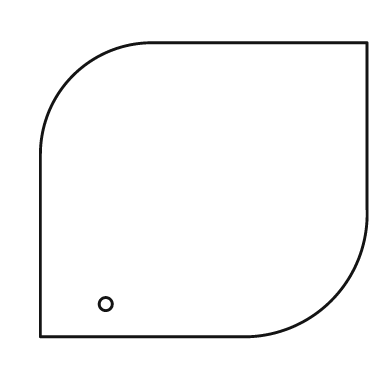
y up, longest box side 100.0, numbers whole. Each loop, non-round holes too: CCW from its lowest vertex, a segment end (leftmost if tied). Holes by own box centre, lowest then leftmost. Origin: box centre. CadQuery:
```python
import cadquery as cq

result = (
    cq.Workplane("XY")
    .moveTo(-50.0, -45.0)
    .lineTo(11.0, -45.0)
    .threePointArc((39.0, -34.0), (50.0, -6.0))
    .lineTo(50.0, 45.0)
    .lineTo(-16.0, 45.0)
    .threePointArc((-40.0, 35.0), (-50.0, 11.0))
    .close()
    .moveTo(-30.0, -35.0)
    .circle(2.0)
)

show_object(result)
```